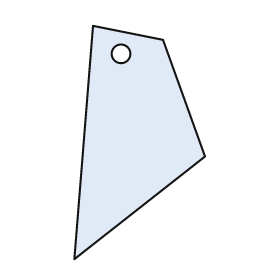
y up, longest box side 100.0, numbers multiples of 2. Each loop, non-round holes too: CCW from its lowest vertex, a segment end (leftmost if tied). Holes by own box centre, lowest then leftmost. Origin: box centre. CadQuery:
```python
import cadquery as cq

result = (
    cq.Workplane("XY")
    .moveTo(-28.0, -50.0)
    .lineTo(28.0, -6.0)
    .lineTo(10.0, 44.0)
    .lineTo(-20.0, 50.0)
    .close()
    .moveTo(-8.0, 38.0)
    .circle(4.0)
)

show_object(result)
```